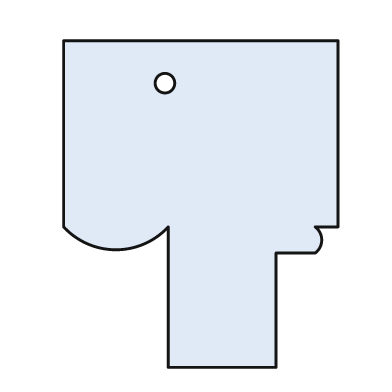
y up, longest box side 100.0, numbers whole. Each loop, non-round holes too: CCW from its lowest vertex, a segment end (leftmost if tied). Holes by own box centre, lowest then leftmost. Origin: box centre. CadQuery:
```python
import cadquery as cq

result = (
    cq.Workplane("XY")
    .moveTo(-10.0, -50.0)
    .lineTo(23.0, -50.0)
    .lineTo(23.0, -15.0)
    .lineTo(35.0, -15.0)
    .threePointArc((37.0, -11.0), (35.0, -7.0))
    .lineTo(42.0, -7.0)
    .lineTo(42.0, 50.0)
    .lineTo(-42.0, 50.0)
    .lineTo(-42.0, -7.0)
    .threePointArc((-26.0, -14.0), (-10.0, -7.0))
    .close()
    .moveTo(-11.0, 37.0)
    .circle(3.0)
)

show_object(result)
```